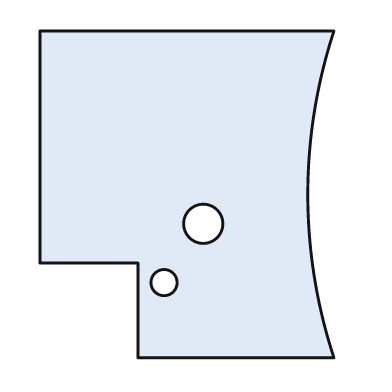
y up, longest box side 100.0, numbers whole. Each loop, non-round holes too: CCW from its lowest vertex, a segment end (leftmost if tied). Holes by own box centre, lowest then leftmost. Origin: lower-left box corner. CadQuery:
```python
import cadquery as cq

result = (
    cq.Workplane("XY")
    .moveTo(30.0, 0.0)
    .lineTo(90.0, 0.0)
    .threePointArc((82.0, 50.0), (90.0, 100.0))
    .lineTo(0.0, 100.0)
    .lineTo(0.0, 29.0)
    .lineTo(30.0, 29.0)
    .close()
    .moveTo(38.0, 23.0)
    .circle(4.0)
    .moveTo(50.0, 41.0)
    .circle(6.0)
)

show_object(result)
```